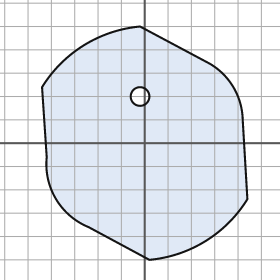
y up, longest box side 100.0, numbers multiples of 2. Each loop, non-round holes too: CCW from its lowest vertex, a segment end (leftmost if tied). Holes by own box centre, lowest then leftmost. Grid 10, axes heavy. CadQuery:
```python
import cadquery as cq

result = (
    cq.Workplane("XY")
    .moveTo(2.0, -50.0)
    .threePointArc((26.0, -42.0), (44.0, -24.0))
    .lineTo(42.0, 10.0)
    .threePointArc((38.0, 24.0), (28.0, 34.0))
    .lineTo(-2.0, 50.0)
    .threePointArc((-26.0, 42.0), (-44.0, 24.0))
    .lineTo(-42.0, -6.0)
    .threePointArc((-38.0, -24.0), (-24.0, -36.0))
    .close()
    .moveTo(-2.0, 20.0)
    .circle(4.0)
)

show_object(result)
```